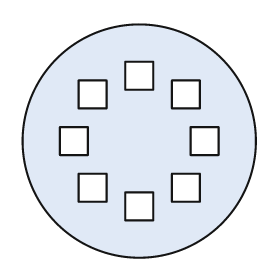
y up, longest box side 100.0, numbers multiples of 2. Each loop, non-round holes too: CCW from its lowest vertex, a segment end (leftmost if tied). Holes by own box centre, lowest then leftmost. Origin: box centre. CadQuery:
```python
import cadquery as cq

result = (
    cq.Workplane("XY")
    .moveTo(0.0, 0.0)
    .circle(50.0)
    .moveTo(-6.0, -34.0)
    .lineTo(6.0, -34.0)
    .lineTo(6.0, -22.0)
    .lineTo(-6.0, -22.0)
    .close()
    .moveTo(-26.0, -26.0)
    .lineTo(-14.0, -26.0)
    .lineTo(-14.0, -14.0)
    .lineTo(-26.0, -14.0)
    .close()
    .moveTo(14.0, -26.0)
    .lineTo(26.0, -26.0)
    .lineTo(26.0, -14.0)
    .lineTo(14.0, -14.0)
    .close()
    .moveTo(-34.0, -6.0)
    .lineTo(-22.0, -6.0)
    .lineTo(-22.0, 6.0)
    .lineTo(-34.0, 6.0)
    .close()
    .moveTo(22.0, -6.0)
    .lineTo(34.0, -6.0)
    .lineTo(34.0, 6.0)
    .lineTo(22.0, 6.0)
    .close()
    .moveTo(-26.0, 14.0)
    .lineTo(-14.0, 14.0)
    .lineTo(-14.0, 26.0)
    .lineTo(-26.0, 26.0)
    .close()
    .moveTo(14.0, 14.0)
    .lineTo(26.0, 14.0)
    .lineTo(26.0, 26.0)
    .lineTo(14.0, 26.0)
    .close()
    .moveTo(-6.0, 22.0)
    .lineTo(6.0, 22.0)
    .lineTo(6.0, 34.0)
    .lineTo(-6.0, 34.0)
    .close()
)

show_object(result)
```